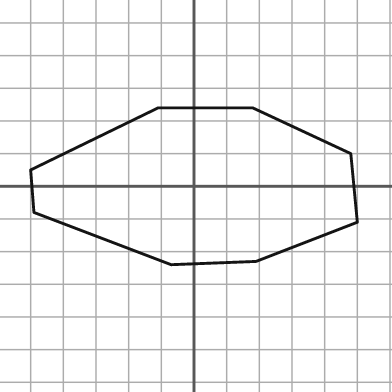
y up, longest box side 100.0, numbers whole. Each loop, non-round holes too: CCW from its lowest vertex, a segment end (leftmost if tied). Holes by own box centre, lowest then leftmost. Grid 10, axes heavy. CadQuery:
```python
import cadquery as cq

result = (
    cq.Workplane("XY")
    .moveTo(-7.0, -24.0)
    .lineTo(19.0, -23.0)
    .lineTo(50.0, -11.0)
    .lineTo(48.0, 10.0)
    .lineTo(18.0, 24.0)
    .lineTo(-11.0, 24.0)
    .lineTo(-50.0, 5.0)
    .lineTo(-49.0, -8.0)
    .close()
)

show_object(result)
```